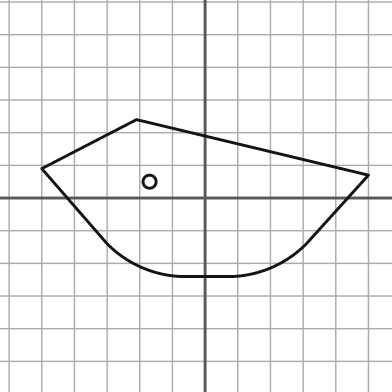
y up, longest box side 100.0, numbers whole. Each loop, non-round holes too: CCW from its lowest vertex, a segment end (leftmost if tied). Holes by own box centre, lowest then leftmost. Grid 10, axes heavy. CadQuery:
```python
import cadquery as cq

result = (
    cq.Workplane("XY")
    .moveTo(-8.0, -24.0)
    .lineTo(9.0, -24.0)
    .threePointArc((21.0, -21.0), (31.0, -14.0))
    .lineTo(50.0, 7.0)
    .lineTo(-21.0, 24.0)
    .lineTo(-50.0, 9.0)
    .lineTo(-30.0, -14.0)
    .threePointArc((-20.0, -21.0), (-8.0, -24.0))
    .close()
    .moveTo(-17.0, 5.0)
    .circle(2.0)
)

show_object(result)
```